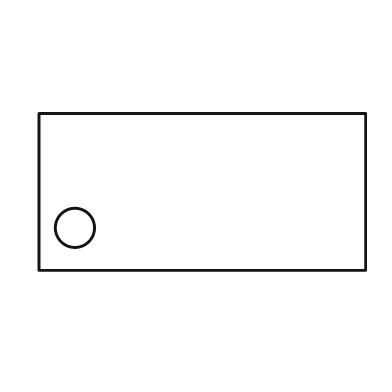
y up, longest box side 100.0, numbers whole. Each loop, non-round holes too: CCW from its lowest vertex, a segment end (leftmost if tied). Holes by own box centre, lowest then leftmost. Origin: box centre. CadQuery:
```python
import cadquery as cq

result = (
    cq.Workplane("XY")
    .moveTo(-50.0, -24.0)
    .lineTo(50.0, -24.0)
    .lineTo(50.0, 24.0)
    .lineTo(-50.0, 24.0)
    .close()
    .moveTo(-39.0, -11.0)
    .circle(6.0)
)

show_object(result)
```